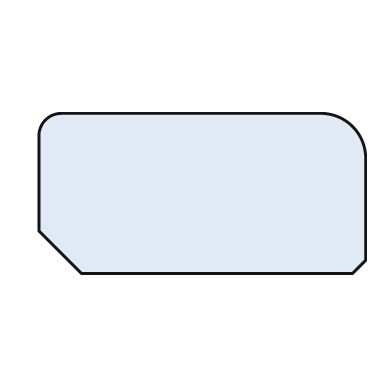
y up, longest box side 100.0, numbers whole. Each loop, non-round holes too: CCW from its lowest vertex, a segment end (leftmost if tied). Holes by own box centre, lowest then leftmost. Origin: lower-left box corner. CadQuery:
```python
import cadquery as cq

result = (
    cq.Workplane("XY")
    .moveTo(13.0, 0.0)
    .lineTo(96.0, 0.0)
    .lineTo(100.0, 4.0)
    .lineTo(100.0, 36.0)
    .threePointArc((96.0, 45.0), (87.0, 49.0))
    .lineTo(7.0, 49.0)
    .threePointArc((2.0, 47.0), (0.0, 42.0))
    .lineTo(0.0, 13.0)
    .close()
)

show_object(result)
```